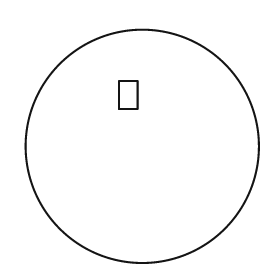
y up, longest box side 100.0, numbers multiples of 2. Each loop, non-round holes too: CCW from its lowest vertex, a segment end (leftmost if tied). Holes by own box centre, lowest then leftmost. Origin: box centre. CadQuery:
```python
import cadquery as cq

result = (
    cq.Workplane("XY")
    .moveTo(0.0, 0.0)
    .circle(50.0)
    .moveTo(-10.0, 16.0)
    .lineTo(-2.0, 16.0)
    .lineTo(-2.0, 28.0)
    .lineTo(-10.0, 28.0)
    .close()
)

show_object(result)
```